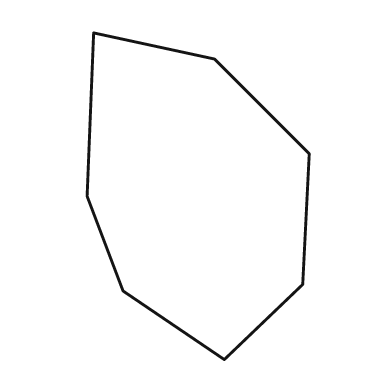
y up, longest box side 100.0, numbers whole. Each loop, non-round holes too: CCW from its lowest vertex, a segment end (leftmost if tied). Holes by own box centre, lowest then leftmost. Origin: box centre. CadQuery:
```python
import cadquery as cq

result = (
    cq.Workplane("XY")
    .moveTo(8.0, -50.0)
    .lineTo(32.0, -27.0)
    .lineTo(34.0, 13.0)
    .lineTo(5.0, 42.0)
    .lineTo(-32.0, 50.0)
    .lineTo(-34.0, 0.0)
    .lineTo(-23.0, -29.0)
    .close()
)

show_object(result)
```